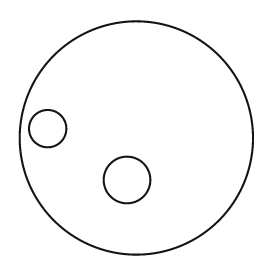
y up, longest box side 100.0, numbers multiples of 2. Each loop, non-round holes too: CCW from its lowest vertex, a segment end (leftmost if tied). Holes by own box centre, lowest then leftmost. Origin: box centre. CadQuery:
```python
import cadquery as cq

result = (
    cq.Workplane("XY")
    .moveTo(0.0, 0.0)
    .circle(50.0)
    .moveTo(-4.0, -18.0)
    .circle(10.0)
    .moveTo(-38.0, 4.0)
    .circle(8.0)
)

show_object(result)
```